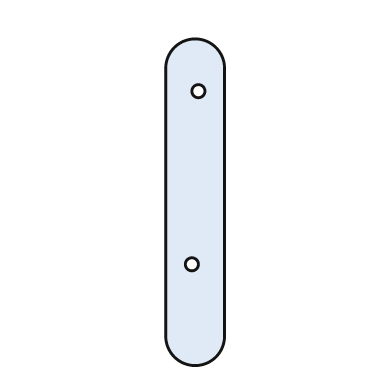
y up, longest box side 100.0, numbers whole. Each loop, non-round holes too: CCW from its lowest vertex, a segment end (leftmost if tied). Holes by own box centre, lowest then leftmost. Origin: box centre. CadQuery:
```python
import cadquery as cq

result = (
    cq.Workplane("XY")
    .moveTo(-9.0, -41.0)
    .threePointArc((0.0, -50.0), (9.0, -41.0))
    .lineTo(9.0, 41.0)
    .threePointArc((0.0, 50.0), (-9.0, 41.0))
    .close()
    .moveTo(-1.0, -19.0)
    .circle(2.0)
    .moveTo(1.0, 34.0)
    .circle(2.0)
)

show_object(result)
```